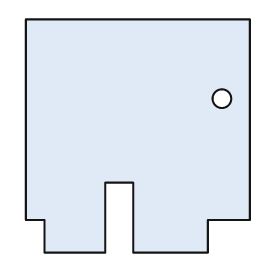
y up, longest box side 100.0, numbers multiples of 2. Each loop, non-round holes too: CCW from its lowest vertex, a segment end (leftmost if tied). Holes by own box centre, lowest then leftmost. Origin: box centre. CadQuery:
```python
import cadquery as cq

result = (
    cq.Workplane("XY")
    .moveTo(-40.0, -50.0)
    .lineTo(-14.0, -50.0)
    .lineTo(-14.0, -20.0)
    .lineTo(-2.0, -20.0)
    .lineTo(-2.0, -50.0)
    .lineTo(30.0, -50.0)
    .lineTo(30.0, -36.0)
    .lineTo(48.0, -36.0)
    .lineTo(48.0, 50.0)
    .lineTo(-48.0, 50.0)
    .lineTo(-48.0, -36.0)
    .lineTo(-40.0, -36.0)
    .close()
    .moveTo(36.0, 16.0)
    .circle(4.0)
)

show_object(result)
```